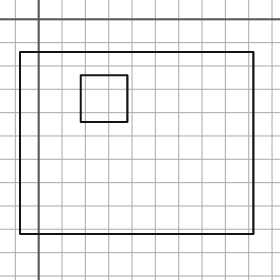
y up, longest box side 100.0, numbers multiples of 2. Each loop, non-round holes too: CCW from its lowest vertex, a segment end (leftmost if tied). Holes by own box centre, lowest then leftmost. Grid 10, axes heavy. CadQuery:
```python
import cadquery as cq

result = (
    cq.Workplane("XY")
    .moveTo(-8.0, -92.0)
    .lineTo(92.0, -92.0)
    .lineTo(92.0, -14.0)
    .lineTo(-8.0, -14.0)
    .close()
    .moveTo(18.0, -44.0)
    .lineTo(38.0, -44.0)
    .lineTo(38.0, -24.0)
    .lineTo(18.0, -24.0)
    .close()
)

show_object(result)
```